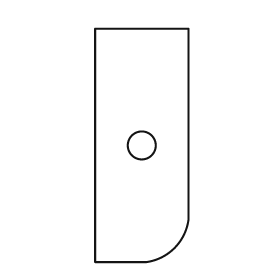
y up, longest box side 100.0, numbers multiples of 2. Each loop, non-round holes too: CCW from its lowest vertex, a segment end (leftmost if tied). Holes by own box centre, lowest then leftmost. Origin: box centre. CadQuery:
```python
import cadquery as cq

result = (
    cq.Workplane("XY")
    .moveTo(-20.0, -50.0)
    .lineTo(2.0, -50.0)
    .threePointArc((14.0, -44.0), (20.0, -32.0))
    .lineTo(20.0, 50.0)
    .lineTo(-20.0, 50.0)
    .close()
    .moveTo(0.0, 0.0)
    .circle(6.0)
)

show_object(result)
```